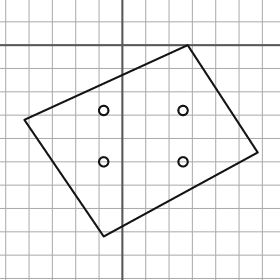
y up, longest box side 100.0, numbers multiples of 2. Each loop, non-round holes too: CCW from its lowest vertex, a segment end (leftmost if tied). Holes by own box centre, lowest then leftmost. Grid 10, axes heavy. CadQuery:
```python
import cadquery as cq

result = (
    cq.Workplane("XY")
    .moveTo(-8.0, -82.0)
    .lineTo(58.0, -46.0)
    .lineTo(28.0, 0.0)
    .lineTo(-42.0, -32.0)
    .close()
    .moveTo(-8.0, -50.0)
    .circle(2.0)
    .moveTo(26.0, -50.0)
    .circle(2.0)
    .moveTo(-8.0, -28.0)
    .circle(2.0)
    .moveTo(26.0, -28.0)
    .circle(2.0)
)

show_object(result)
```